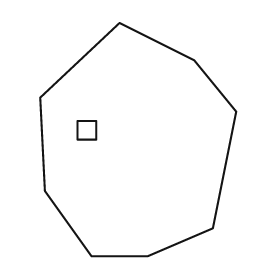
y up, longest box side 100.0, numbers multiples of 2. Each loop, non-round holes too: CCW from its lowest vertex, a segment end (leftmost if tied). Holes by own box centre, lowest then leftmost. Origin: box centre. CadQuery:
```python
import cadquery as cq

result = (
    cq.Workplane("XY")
    .moveTo(-20.0, -50.0)
    .lineTo(4.0, -50.0)
    .lineTo(32.0, -38.0)
    .lineTo(42.0, 12.0)
    .lineTo(24.0, 34.0)
    .lineTo(-8.0, 50.0)
    .lineTo(-42.0, 18.0)
    .lineTo(-40.0, -22.0)
    .close()
    .moveTo(-26.0, 0.0)
    .lineTo(-18.0, 0.0)
    .lineTo(-18.0, 8.0)
    .lineTo(-26.0, 8.0)
    .close()
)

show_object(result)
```